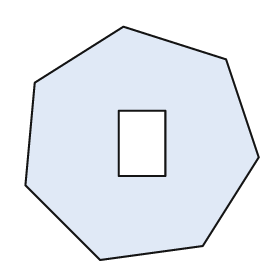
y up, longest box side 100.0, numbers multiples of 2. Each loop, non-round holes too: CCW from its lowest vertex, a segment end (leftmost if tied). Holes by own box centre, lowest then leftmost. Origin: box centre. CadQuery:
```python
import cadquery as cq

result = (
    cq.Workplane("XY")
    .moveTo(-18.0, -50.0)
    .lineTo(26.0, -44.0)
    .lineTo(50.0, -6.0)
    .lineTo(36.0, 36.0)
    .lineTo(-8.0, 50.0)
    .lineTo(-46.0, 26.0)
    .lineTo(-50.0, -18.0)
    .close()
    .moveTo(-10.0, -14.0)
    .lineTo(10.0, -14.0)
    .lineTo(10.0, 14.0)
    .lineTo(-10.0, 14.0)
    .close()
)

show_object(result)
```